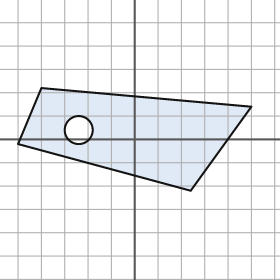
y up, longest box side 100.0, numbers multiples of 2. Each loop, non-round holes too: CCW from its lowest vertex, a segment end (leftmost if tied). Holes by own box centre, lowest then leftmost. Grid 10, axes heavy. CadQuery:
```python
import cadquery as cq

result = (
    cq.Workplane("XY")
    .moveTo(24.0, -22.0)
    .lineTo(50.0, 14.0)
    .lineTo(-40.0, 22.0)
    .lineTo(-50.0, -2.0)
    .close()
    .moveTo(-24.0, 4.0)
    .circle(6.0)
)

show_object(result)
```